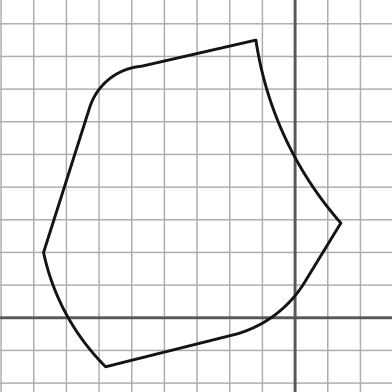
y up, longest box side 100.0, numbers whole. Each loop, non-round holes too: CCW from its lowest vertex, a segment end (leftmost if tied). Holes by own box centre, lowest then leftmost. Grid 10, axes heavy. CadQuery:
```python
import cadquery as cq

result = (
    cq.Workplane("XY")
    .moveTo(-58.0, -15.0)
    .lineTo(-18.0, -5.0)
    .threePointArc((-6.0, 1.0), (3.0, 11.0))
    .lineTo(14.0, 29.0)
    .threePointArc((-3.0, 55.0), (-12.0, 85.0))
    .lineTo(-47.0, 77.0)
    .threePointArc((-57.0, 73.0), (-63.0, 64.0))
    .lineTo(-77.0, 20.0)
    .threePointArc((-70.0, 1.0), (-58.0, -15.0))
    .close()
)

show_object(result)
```